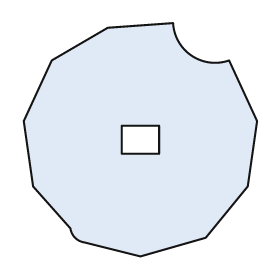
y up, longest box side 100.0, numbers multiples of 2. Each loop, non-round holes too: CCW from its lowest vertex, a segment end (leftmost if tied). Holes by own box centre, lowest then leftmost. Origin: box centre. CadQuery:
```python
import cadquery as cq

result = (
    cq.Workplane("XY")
    .moveTo(0.0, -50.0)
    .lineTo(28.0, -42.0)
    .lineTo(46.0, -20.0)
    .lineTo(50.0, 8.0)
    .lineTo(38.0, 34.0)
    .threePointArc((22.0, 36.0), (14.0, 50.0))
    .lineTo(-14.0, 48.0)
    .lineTo(-38.0, 34.0)
    .lineTo(-50.0, 8.0)
    .lineTo(-46.0, -20.0)
    .lineTo(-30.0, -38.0)
    .threePointArc((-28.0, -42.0), (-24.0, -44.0))
    .close()
    .moveTo(-8.0, -6.0)
    .lineTo(8.0, -6.0)
    .lineTo(8.0, 6.0)
    .lineTo(-8.0, 6.0)
    .close()
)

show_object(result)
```